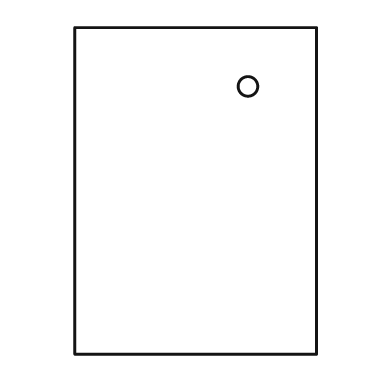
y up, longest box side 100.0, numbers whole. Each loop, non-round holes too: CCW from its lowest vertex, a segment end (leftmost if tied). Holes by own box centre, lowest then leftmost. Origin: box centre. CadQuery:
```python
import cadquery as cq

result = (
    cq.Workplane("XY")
    .moveTo(-37.0, -50.0)
    .lineTo(37.0, -50.0)
    .lineTo(37.0, 50.0)
    .lineTo(-37.0, 50.0)
    .close()
    .moveTo(16.0, 32.0)
    .circle(3.0)
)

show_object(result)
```